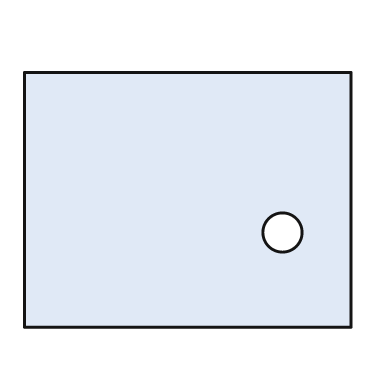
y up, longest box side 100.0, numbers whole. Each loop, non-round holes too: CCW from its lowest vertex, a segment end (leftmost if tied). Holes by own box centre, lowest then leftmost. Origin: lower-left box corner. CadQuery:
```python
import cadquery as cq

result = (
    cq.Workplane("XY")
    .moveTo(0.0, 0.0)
    .lineTo(100.0, 0.0)
    .lineTo(100.0, 78.0)
    .lineTo(0.0, 78.0)
    .close()
    .moveTo(79.0, 29.0)
    .circle(6.0)
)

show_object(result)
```